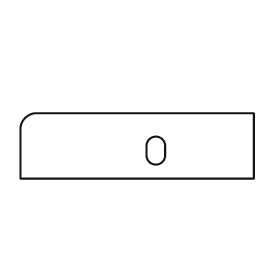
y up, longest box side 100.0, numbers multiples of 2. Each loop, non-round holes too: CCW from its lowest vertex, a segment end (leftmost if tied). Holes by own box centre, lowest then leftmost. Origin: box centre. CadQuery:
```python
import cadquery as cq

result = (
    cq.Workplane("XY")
    .moveTo(-50.0, -14.0)
    .lineTo(50.0, -14.0)
    .lineTo(50.0, 14.0)
    .lineTo(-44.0, 14.0)
    .threePointArc((-48.0, 12.0), (-50.0, 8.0))
    .close()
    .moveTo(4.0, -4.0)
    .threePointArc((8.0, -8.0), (12.0, -4.0))
    .lineTo(12.0, 0.0)
    .threePointArc((8.0, 4.0), (4.0, 0.0))
    .close()
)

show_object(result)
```